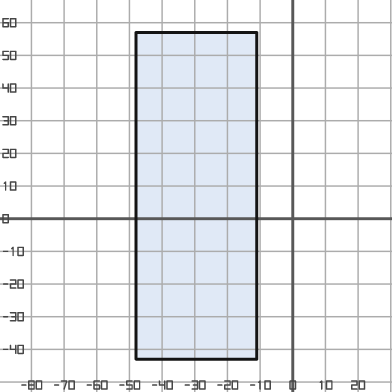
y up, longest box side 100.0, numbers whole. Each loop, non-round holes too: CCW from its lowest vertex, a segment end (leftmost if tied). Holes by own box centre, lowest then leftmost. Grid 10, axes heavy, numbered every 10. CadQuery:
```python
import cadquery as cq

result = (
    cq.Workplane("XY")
    .moveTo(-48.0, -43.0)
    .lineTo(-11.0, -43.0)
    .lineTo(-11.0, 57.0)
    .lineTo(-48.0, 57.0)
    .close()
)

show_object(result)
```